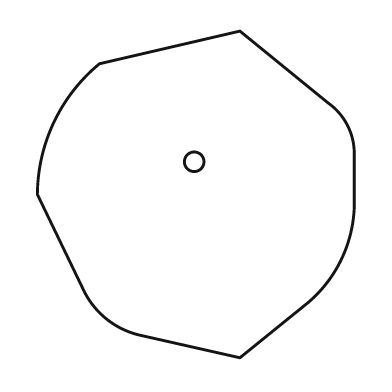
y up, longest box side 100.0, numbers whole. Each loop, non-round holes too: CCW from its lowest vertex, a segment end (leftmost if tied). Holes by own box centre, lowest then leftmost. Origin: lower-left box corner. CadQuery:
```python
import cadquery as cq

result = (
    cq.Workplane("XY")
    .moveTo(62.0, 0.0)
    .lineTo(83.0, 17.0)
    .threePointArc((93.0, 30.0), (97.0, 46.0))
    .lineTo(97.0, 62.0)
    .threePointArc((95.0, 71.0), (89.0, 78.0))
    .lineTo(62.0, 100.0)
    .lineTo(19.0, 90.0)
    .threePointArc((5.0, 72.0), (0.0, 50.0))
    .lineTo(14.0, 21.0)
    .threePointArc((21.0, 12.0), (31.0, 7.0))
    .close()
    .moveTo(48.0, 60.0)
    .circle(3.0)
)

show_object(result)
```